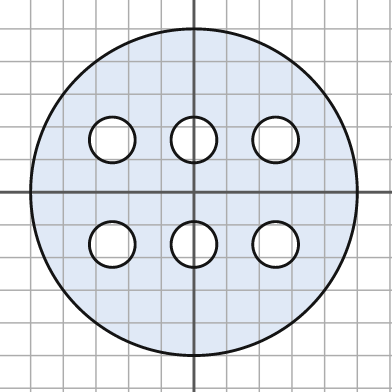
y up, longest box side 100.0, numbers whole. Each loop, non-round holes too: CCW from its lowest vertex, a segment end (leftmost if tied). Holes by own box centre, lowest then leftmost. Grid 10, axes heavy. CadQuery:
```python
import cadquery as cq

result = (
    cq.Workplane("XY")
    .moveTo(0.0, 0.0)
    .circle(50.0)
    .moveTo(-25.0, -16.0)
    .circle(7.0)
    .moveTo(0.0, -16.0)
    .circle(7.0)
    .moveTo(25.0, -16.0)
    .circle(7.0)
    .moveTo(-25.0, 16.0)
    .circle(7.0)
    .moveTo(0.0, 16.0)
    .circle(7.0)
    .moveTo(25.0, 16.0)
    .circle(7.0)
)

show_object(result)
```